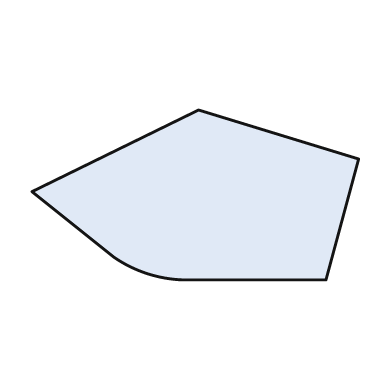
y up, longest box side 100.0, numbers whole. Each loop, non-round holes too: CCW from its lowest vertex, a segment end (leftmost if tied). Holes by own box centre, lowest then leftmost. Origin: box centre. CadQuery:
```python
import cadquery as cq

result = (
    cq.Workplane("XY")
    .moveTo(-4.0, -26.0)
    .lineTo(40.0, -26.0)
    .lineTo(50.0, 11.0)
    .lineTo(1.0, 26.0)
    .lineTo(-50.0, 1.0)
    .lineTo(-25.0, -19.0)
    .threePointArc((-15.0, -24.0), (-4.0, -26.0))
    .close()
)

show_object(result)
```